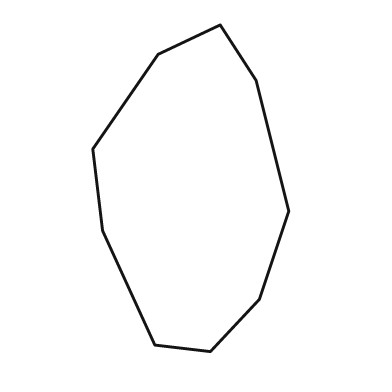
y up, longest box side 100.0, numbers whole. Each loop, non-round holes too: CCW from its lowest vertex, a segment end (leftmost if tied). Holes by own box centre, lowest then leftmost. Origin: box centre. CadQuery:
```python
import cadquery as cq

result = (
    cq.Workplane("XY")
    .moveTo(6.0, -50.0)
    .lineTo(21.0, -34.0)
    .lineTo(30.0, -7.0)
    .lineTo(20.0, 33.0)
    .lineTo(9.0, 50.0)
    .lineTo(-10.0, 41.0)
    .lineTo(-30.0, 12.0)
    .lineTo(-27.0, -13.0)
    .lineTo(-11.0, -48.0)
    .close()
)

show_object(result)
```